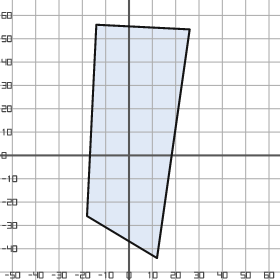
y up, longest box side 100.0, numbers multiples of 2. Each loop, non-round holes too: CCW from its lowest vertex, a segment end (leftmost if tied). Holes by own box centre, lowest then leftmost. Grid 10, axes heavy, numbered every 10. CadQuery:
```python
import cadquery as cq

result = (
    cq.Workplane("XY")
    .moveTo(12.0, -44.0)
    .lineTo(26.0, 54.0)
    .lineTo(-14.0, 56.0)
    .lineTo(-18.0, -26.0)
    .close()
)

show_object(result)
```